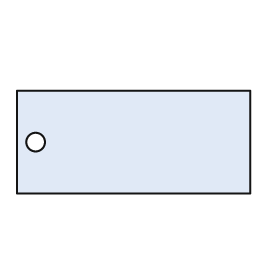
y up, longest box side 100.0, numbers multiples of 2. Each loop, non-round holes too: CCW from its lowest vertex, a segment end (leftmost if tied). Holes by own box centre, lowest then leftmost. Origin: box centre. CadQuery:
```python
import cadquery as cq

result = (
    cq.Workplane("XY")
    .moveTo(-50.0, -22.0)
    .lineTo(50.0, -22.0)
    .lineTo(50.0, 22.0)
    .lineTo(-50.0, 22.0)
    .close()
    .moveTo(-42.0, 0.0)
    .circle(4.0)
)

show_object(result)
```